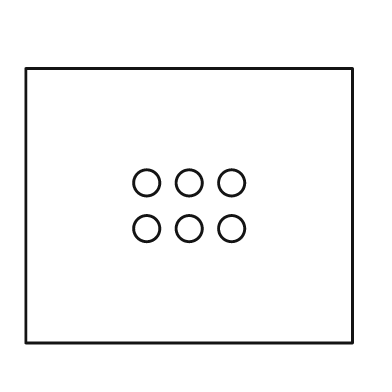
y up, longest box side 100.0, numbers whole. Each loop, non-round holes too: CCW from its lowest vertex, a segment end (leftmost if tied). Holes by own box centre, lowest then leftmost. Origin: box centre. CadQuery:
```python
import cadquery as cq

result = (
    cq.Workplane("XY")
    .moveTo(-50.0, -42.0)
    .lineTo(50.0, -42.0)
    .lineTo(50.0, 42.0)
    .lineTo(-50.0, 42.0)
    .close()
    .moveTo(-13.0, -7.0)
    .circle(4.0)
    .moveTo(0.0, -7.0)
    .circle(4.0)
    .moveTo(13.0, -7.0)
    .circle(4.0)
    .moveTo(-13.0, 7.0)
    .circle(4.0)
    .moveTo(0.0, 7.0)
    .circle(4.0)
    .moveTo(13.0, 7.0)
    .circle(4.0)
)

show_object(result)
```